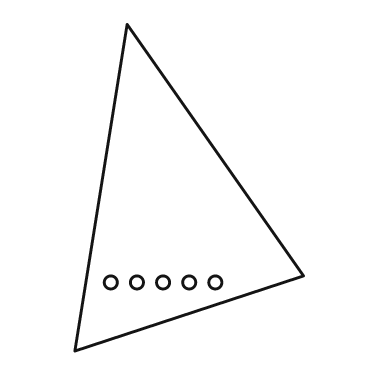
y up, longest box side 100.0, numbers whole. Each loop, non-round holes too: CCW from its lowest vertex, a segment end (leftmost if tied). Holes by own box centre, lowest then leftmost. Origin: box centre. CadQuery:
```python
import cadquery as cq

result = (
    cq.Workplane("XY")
    .moveTo(-35.0, -50.0)
    .lineTo(35.0, -27.0)
    .lineTo(-19.0, 50.0)
    .close()
    .moveTo(-24.0, -29.0)
    .circle(2.0)
    .moveTo(-16.0, -29.0)
    .circle(2.0)
    .moveTo(-8.0, -29.0)
    .circle(2.0)
    .moveTo(0.0, -29.0)
    .circle(2.0)
    .moveTo(8.0, -29.0)
    .circle(2.0)
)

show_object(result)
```